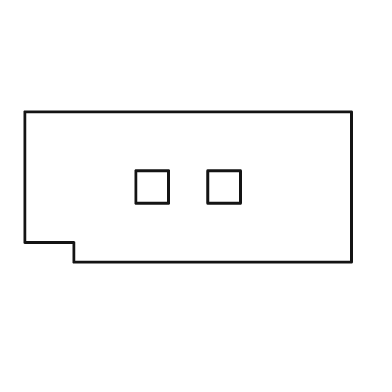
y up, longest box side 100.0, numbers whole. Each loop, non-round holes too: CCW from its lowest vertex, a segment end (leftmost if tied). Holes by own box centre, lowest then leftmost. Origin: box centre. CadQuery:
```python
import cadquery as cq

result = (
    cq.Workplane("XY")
    .moveTo(-35.0, -23.0)
    .lineTo(50.0, -23.0)
    .lineTo(50.0, 23.0)
    .lineTo(-50.0, 23.0)
    .lineTo(-50.0, -17.0)
    .lineTo(-35.0, -17.0)
    .close()
    .moveTo(-16.0, -5.0)
    .lineTo(-6.0, -5.0)
    .lineTo(-6.0, 5.0)
    .lineTo(-16.0, 5.0)
    .close()
    .moveTo(6.0, -5.0)
    .lineTo(16.0, -5.0)
    .lineTo(16.0, 5.0)
    .lineTo(6.0, 5.0)
    .close()
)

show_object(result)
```